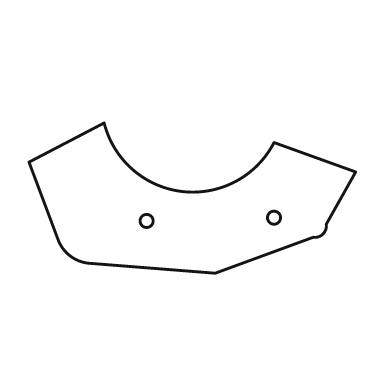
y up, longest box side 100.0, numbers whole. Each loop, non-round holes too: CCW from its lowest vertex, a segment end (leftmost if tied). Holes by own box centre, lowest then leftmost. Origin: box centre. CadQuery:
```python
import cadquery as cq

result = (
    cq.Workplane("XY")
    .moveTo(7.0, -23.0)
    .lineTo(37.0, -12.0)
    .threePointArc((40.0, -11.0), (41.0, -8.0))
    .lineTo(50.0, 8.0)
    .lineTo(25.0, 17.0)
    .threePointArc((-3.0, 2.0), (-27.0, 23.0))
    .lineTo(-50.0, 11.0)
    .lineTo(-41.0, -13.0)
    .threePointArc((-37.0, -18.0), (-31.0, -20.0))
    .close()
    .moveTo(-14.0, -7.0)
    .circle(2.0)
    .moveTo(25.0, -6.0)
    .circle(2.0)
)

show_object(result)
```